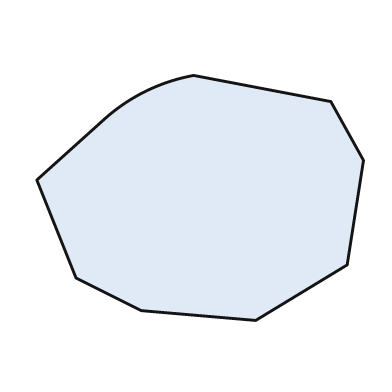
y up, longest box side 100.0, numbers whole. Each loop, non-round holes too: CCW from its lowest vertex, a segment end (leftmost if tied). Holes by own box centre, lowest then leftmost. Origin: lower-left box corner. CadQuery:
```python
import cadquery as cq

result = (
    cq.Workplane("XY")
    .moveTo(67.0, 0.0)
    .lineTo(95.0, 17.0)
    .lineTo(100.0, 49.0)
    .lineTo(90.0, 67.0)
    .lineTo(48.0, 75.0)
    .threePointArc((33.0, 70.0), (20.0, 61.0))
    .lineTo(0.0, 43.0)
    .lineTo(12.0, 13.0)
    .lineTo(32.0, 3.0)
    .close()
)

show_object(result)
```